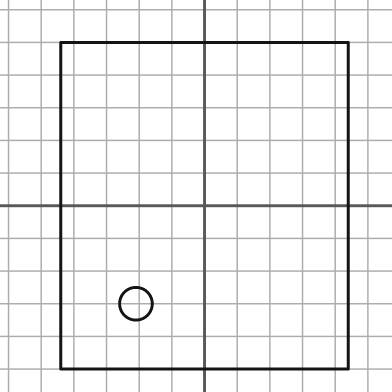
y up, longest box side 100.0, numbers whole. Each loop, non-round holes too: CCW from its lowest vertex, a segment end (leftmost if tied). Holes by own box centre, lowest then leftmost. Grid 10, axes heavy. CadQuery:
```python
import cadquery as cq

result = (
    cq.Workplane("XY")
    .moveTo(-44.0, -50.0)
    .lineTo(44.0, -50.0)
    .lineTo(44.0, 50.0)
    .lineTo(-44.0, 50.0)
    .close()
    .moveTo(-21.0, -30.0)
    .circle(5.0)
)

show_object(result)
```